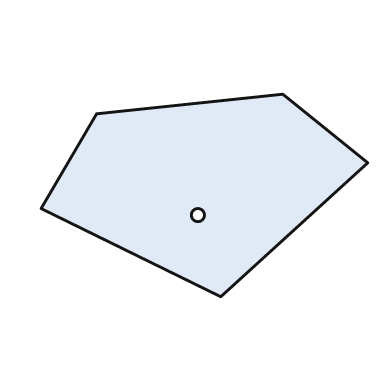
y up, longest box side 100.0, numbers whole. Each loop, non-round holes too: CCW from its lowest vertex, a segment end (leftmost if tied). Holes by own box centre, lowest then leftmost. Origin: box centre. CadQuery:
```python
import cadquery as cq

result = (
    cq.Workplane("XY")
    .moveTo(5.0, -31.0)
    .lineTo(50.0, 10.0)
    .lineTo(24.0, 31.0)
    .lineTo(-33.0, 25.0)
    .lineTo(-50.0, -4.0)
    .close()
    .moveTo(-2.0, -6.0)
    .circle(2.0)
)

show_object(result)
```